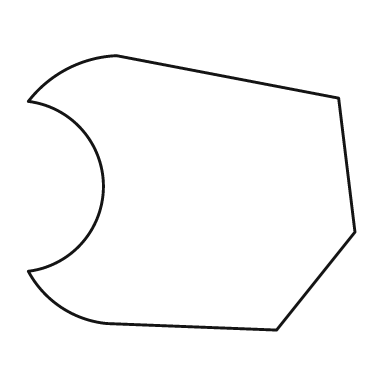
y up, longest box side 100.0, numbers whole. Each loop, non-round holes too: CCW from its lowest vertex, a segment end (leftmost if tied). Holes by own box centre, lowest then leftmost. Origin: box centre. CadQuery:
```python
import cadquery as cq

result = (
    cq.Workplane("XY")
    .moveTo(26.0, -42.0)
    .lineTo(50.0, -12.0)
    .lineTo(45.0, 29.0)
    .lineTo(-23.0, 42.0)
    .threePointArc((-38.0, 38.0), (-50.0, 28.0))
    .threePointArc((-27.0, 2.0), (-50.0, -24.0))
    .threePointArc((-40.0, -35.0), (-26.0, -40.0))
    .close()
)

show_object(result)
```